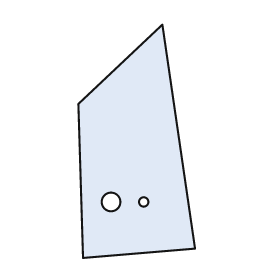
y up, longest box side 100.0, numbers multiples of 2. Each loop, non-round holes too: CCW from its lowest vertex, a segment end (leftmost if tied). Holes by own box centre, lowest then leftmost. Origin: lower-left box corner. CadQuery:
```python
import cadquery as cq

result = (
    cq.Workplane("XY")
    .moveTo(2.0, 0.0)
    .lineTo(50.0, 4.0)
    .lineTo(36.0, 100.0)
    .lineTo(0.0, 66.0)
    .close()
    .moveTo(14.0, 24.0)
    .circle(4.0)
    .moveTo(28.0, 24.0)
    .circle(2.0)
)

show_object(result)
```